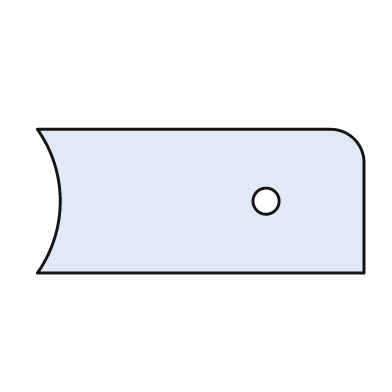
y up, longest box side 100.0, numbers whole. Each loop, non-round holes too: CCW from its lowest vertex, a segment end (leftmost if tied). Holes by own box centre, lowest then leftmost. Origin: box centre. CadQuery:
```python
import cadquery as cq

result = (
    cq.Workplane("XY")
    .moveTo(-50.0, -22.0)
    .lineTo(50.0, -22.0)
    .lineTo(50.0, 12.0)
    .threePointArc((47.0, 19.0), (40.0, 22.0))
    .lineTo(-50.0, 22.0)
    .threePointArc((-43.0, 0.0), (-50.0, -22.0))
    .close()
    .moveTo(20.0, 0.0)
    .circle(4.0)
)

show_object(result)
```